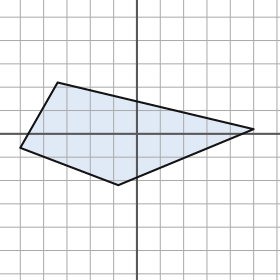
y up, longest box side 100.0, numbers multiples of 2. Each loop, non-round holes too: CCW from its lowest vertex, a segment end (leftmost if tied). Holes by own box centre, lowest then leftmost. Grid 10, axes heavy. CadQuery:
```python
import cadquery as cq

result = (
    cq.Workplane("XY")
    .moveTo(-8.0, -22.0)
    .lineTo(50.0, 2.0)
    .lineTo(-34.0, 22.0)
    .lineTo(-50.0, -6.0)
    .close()
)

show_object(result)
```